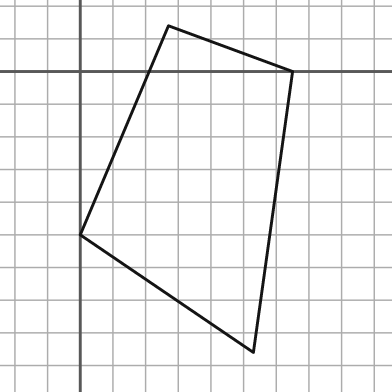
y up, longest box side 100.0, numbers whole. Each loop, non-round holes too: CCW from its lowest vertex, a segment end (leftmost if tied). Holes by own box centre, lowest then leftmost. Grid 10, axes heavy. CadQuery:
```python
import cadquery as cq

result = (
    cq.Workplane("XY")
    .moveTo(53.0, -86.0)
    .lineTo(65.0, 0.0)
    .lineTo(27.0, 14.0)
    .lineTo(0.0, -50.0)
    .close()
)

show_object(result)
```